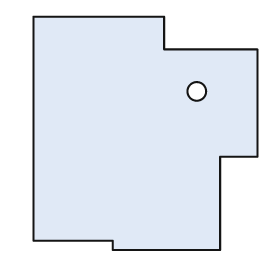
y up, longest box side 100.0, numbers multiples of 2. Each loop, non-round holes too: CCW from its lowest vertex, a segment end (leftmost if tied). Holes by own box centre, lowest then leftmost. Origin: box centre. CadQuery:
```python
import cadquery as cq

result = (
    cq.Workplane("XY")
    .moveTo(-14.0, -50.0)
    .lineTo(32.0, -50.0)
    .lineTo(32.0, -10.0)
    .lineTo(48.0, -10.0)
    .lineTo(48.0, 36.0)
    .lineTo(8.0, 36.0)
    .lineTo(8.0, 50.0)
    .lineTo(-48.0, 50.0)
    .lineTo(-48.0, -46.0)
    .lineTo(-14.0, -46.0)
    .close()
    .moveTo(22.0, 18.0)
    .circle(4.0)
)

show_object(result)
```